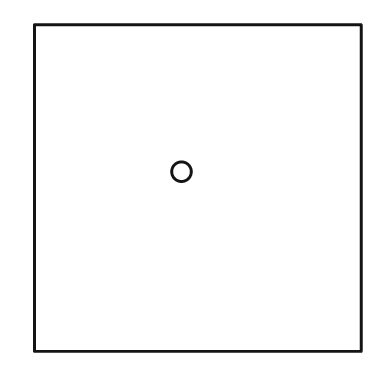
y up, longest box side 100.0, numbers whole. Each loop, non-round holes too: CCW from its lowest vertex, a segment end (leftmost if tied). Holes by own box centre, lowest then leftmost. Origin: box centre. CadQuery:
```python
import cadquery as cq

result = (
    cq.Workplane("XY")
    .moveTo(-50.0, -50.0)
    .lineTo(50.0, -50.0)
    .lineTo(50.0, 50.0)
    .lineTo(-50.0, 50.0)
    .close()
    .moveTo(-5.0, 5.0)
    .circle(3.0)
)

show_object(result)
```